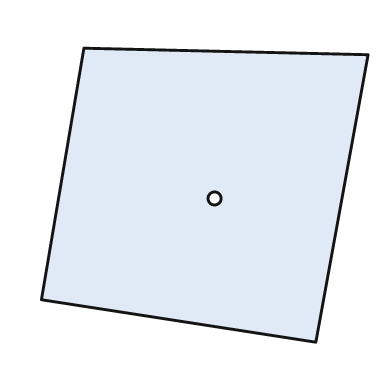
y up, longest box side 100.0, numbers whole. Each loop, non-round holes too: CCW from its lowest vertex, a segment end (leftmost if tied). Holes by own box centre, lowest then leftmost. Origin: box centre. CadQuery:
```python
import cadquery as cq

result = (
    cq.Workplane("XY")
    .moveTo(34.0, -45.0)
    .lineTo(50.0, 43.0)
    .lineTo(-37.0, 45.0)
    .lineTo(-50.0, -32.0)
    .close()
    .moveTo(3.0, -1.0)
    .circle(2.0)
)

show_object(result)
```